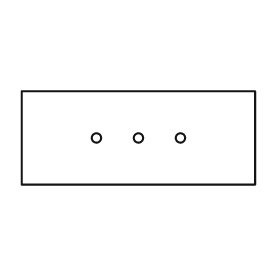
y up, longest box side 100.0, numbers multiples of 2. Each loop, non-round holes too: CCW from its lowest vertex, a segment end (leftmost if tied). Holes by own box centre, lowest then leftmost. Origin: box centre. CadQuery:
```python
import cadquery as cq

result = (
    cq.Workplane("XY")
    .moveTo(-50.0, -20.0)
    .lineTo(50.0, -20.0)
    .lineTo(50.0, 20.0)
    .lineTo(-50.0, 20.0)
    .close()
    .moveTo(-18.0, 0.0)
    .circle(2.0)
    .moveTo(0.0, 0.0)
    .circle(2.0)
    .moveTo(18.0, 0.0)
    .circle(2.0)
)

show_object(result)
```